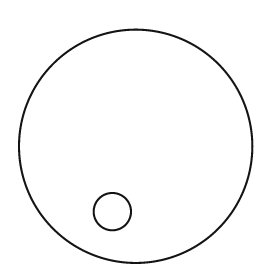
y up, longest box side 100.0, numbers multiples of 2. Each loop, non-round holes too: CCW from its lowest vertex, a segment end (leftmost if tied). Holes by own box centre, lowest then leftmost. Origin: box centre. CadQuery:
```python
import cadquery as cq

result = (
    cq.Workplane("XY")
    .moveTo(0.0, 0.0)
    .circle(50.0)
    .moveTo(-10.0, -28.0)
    .circle(8.0)
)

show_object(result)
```